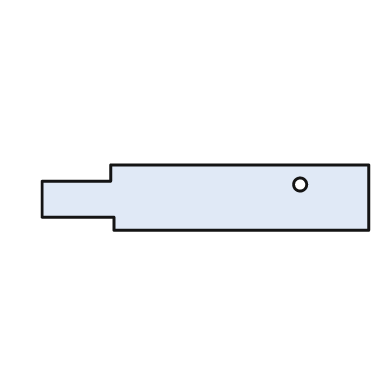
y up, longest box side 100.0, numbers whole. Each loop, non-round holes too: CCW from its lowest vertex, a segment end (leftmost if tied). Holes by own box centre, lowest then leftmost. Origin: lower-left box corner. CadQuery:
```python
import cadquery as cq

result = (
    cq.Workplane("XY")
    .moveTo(22.0, 0.0)
    .lineTo(100.0, 0.0)
    .lineTo(100.0, 20.0)
    .lineTo(21.0, 20.0)
    .lineTo(21.0, 15.0)
    .lineTo(0.0, 15.0)
    .lineTo(0.0, 4.0)
    .lineTo(22.0, 4.0)
    .close()
    .moveTo(79.0, 14.0)
    .circle(2.0)
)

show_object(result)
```